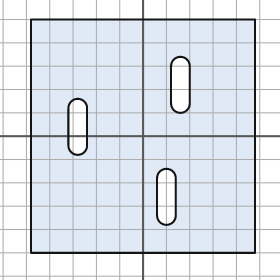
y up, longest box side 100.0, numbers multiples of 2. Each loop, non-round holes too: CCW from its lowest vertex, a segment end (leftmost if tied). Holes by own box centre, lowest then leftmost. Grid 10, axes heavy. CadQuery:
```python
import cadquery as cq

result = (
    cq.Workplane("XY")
    .moveTo(-48.0, -50.0)
    .lineTo(48.0, -50.0)
    .lineTo(48.0, 50.0)
    .lineTo(-48.0, 50.0)
    .close()
    .moveTo(6.0, -34.0)
    .threePointArc((10.0, -38.0), (14.0, -34.0))
    .lineTo(14.0, -18.0)
    .threePointArc((10.0, -14.0), (6.0, -18.0))
    .close()
    .moveTo(-32.0, -4.0)
    .threePointArc((-28.0, -8.0), (-24.0, -4.0))
    .lineTo(-24.0, 12.0)
    .threePointArc((-28.0, 16.0), (-32.0, 12.0))
    .close()
    .moveTo(12.0, 14.0)
    .threePointArc((16.0, 10.0), (20.0, 14.0))
    .lineTo(20.0, 30.0)
    .threePointArc((16.0, 34.0), (12.0, 30.0))
    .close()
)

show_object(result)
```